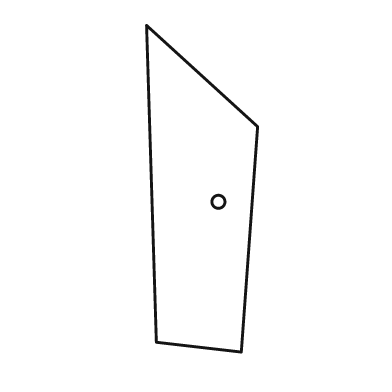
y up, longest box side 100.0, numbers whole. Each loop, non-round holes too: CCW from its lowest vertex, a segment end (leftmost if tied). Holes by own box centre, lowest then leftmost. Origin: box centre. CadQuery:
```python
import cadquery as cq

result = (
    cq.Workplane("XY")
    .moveTo(12.0, -50.0)
    .lineTo(17.0, 19.0)
    .lineTo(-17.0, 50.0)
    .lineTo(-14.0, -47.0)
    .close()
    .moveTo(5.0, -4.0)
    .circle(2.0)
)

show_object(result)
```